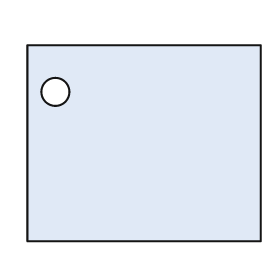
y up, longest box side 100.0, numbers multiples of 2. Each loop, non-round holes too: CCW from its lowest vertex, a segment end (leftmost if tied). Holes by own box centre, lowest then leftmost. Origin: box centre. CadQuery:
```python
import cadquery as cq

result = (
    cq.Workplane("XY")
    .moveTo(-50.0, -42.0)
    .lineTo(50.0, -42.0)
    .lineTo(50.0, 42.0)
    .lineTo(-50.0, 42.0)
    .close()
    .moveTo(-38.0, 22.0)
    .circle(6.0)
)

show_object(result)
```